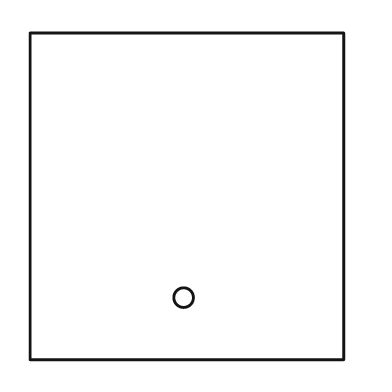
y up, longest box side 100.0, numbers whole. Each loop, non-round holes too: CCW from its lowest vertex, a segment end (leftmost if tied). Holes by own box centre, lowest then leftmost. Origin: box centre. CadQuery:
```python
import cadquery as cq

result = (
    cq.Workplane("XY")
    .moveTo(-48.0, -50.0)
    .lineTo(48.0, -50.0)
    .lineTo(48.0, 50.0)
    .lineTo(-48.0, 50.0)
    .close()
    .moveTo(-1.0, -31.0)
    .circle(3.0)
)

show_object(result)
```